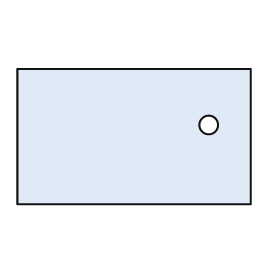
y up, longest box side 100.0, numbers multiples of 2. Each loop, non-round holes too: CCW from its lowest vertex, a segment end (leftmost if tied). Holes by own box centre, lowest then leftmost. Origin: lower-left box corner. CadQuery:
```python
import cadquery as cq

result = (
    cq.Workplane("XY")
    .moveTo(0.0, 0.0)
    .lineTo(100.0, 0.0)
    .lineTo(100.0, 58.0)
    .lineTo(0.0, 58.0)
    .close()
    .moveTo(82.0, 34.0)
    .circle(4.0)
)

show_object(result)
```